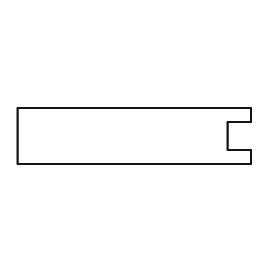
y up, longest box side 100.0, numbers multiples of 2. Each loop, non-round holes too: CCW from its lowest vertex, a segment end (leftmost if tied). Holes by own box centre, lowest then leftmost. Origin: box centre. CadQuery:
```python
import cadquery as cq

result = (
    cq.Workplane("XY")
    .moveTo(-50.0, -12.0)
    .lineTo(50.0, -12.0)
    .lineTo(50.0, -6.0)
    .lineTo(40.0, -6.0)
    .lineTo(40.0, 6.0)
    .lineTo(50.0, 6.0)
    .lineTo(50.0, 12.0)
    .lineTo(-50.0, 12.0)
    .close()
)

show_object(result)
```